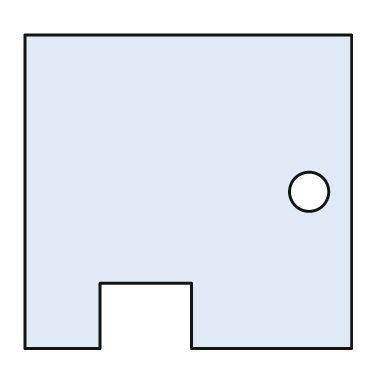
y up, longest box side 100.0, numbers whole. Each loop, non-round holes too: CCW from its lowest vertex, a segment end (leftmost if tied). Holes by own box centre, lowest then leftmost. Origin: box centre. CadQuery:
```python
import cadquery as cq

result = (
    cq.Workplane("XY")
    .moveTo(-50.0, -48.0)
    .lineTo(-27.0, -48.0)
    .lineTo(-27.0, -28.0)
    .lineTo(1.0, -28.0)
    .lineTo(1.0, -48.0)
    .lineTo(50.0, -48.0)
    .lineTo(50.0, 48.0)
    .lineTo(-50.0, 48.0)
    .close()
    .moveTo(37.0, 0.0)
    .circle(6.0)
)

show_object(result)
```